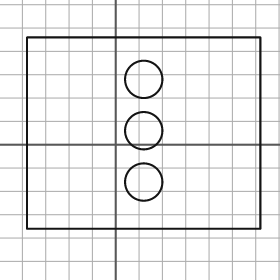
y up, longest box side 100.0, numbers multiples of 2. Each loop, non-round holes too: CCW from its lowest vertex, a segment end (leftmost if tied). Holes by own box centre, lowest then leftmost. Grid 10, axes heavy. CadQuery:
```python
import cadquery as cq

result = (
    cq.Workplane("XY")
    .moveTo(-38.0, -36.0)
    .lineTo(62.0, -36.0)
    .lineTo(62.0, 46.0)
    .lineTo(-38.0, 46.0)
    .close()
    .moveTo(12.0, -16.0)
    .circle(8.0)
    .moveTo(12.0, 6.0)
    .circle(8.0)
    .moveTo(12.0, 28.0)
    .circle(8.0)
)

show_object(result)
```